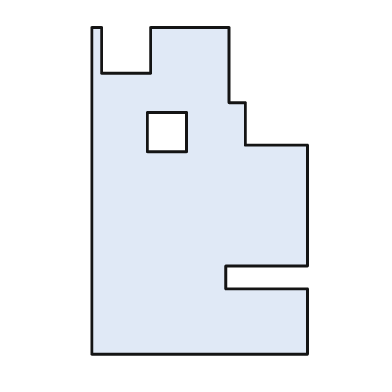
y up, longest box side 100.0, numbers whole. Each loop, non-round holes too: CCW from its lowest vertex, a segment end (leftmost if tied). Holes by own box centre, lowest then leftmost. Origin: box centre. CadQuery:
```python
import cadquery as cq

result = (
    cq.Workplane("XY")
    .moveTo(-33.0, -50.0)
    .lineTo(33.0, -50.0)
    .lineTo(33.0, -30.0)
    .lineTo(8.0, -30.0)
    .lineTo(8.0, -23.0)
    .lineTo(33.0, -23.0)
    .lineTo(33.0, 14.0)
    .lineTo(14.0, 14.0)
    .lineTo(14.0, 27.0)
    .lineTo(9.0, 27.0)
    .lineTo(9.0, 50.0)
    .lineTo(-15.0, 50.0)
    .lineTo(-15.0, 36.0)
    .lineTo(-30.0, 36.0)
    .lineTo(-30.0, 50.0)
    .lineTo(-33.0, 50.0)
    .close()
    .moveTo(-16.0, 12.0)
    .lineTo(-4.0, 12.0)
    .lineTo(-4.0, 24.0)
    .lineTo(-16.0, 24.0)
    .close()
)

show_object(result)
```